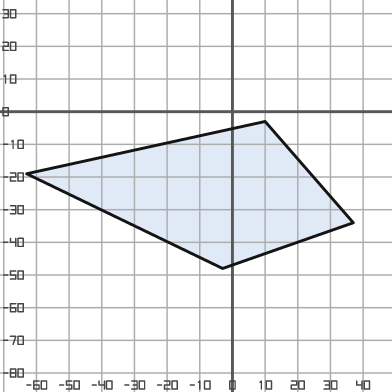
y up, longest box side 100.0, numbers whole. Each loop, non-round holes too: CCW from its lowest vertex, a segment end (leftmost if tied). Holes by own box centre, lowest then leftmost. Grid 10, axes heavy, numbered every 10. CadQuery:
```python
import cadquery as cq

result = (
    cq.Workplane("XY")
    .moveTo(-3.0, -48.0)
    .lineTo(37.0, -34.0)
    .lineTo(10.0, -3.0)
    .lineTo(-63.0, -19.0)
    .close()
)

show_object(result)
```